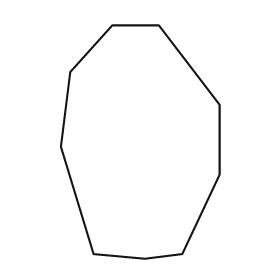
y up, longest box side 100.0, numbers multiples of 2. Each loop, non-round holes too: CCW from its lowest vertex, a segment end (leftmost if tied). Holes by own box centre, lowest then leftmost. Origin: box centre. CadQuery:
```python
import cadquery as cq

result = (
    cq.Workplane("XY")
    .moveTo(2.0, -50.0)
    .lineTo(18.0, -48.0)
    .lineTo(34.0, -14.0)
    .lineTo(34.0, 16.0)
    .lineTo(8.0, 50.0)
    .lineTo(-12.0, 50.0)
    .lineTo(-30.0, 30.0)
    .lineTo(-34.0, -2.0)
    .lineTo(-20.0, -48.0)
    .close()
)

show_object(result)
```